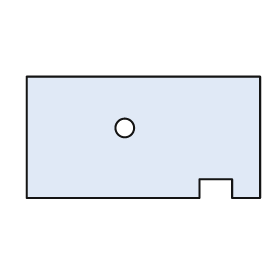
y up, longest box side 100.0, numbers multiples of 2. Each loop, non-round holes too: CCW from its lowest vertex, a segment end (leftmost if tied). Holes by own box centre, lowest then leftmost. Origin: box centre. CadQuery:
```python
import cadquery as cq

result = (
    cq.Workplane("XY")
    .moveTo(-50.0, -26.0)
    .lineTo(24.0, -26.0)
    .lineTo(24.0, -18.0)
    .lineTo(38.0, -18.0)
    .lineTo(38.0, -26.0)
    .lineTo(50.0, -26.0)
    .lineTo(50.0, 26.0)
    .lineTo(-50.0, 26.0)
    .close()
    .moveTo(-8.0, 4.0)
    .circle(4.0)
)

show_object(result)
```